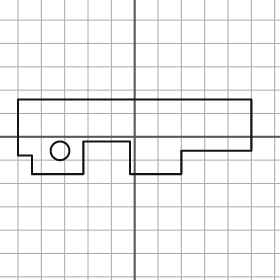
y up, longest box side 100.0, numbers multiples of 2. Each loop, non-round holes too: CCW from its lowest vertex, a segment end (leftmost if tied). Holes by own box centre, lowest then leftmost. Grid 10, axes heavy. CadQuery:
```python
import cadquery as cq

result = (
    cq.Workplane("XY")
    .moveTo(-44.0, -16.0)
    .lineTo(-22.0, -16.0)
    .lineTo(-22.0, -2.0)
    .lineTo(-2.0, -2.0)
    .lineTo(-2.0, -16.0)
    .lineTo(20.0, -16.0)
    .lineTo(20.0, -6.0)
    .lineTo(50.0, -6.0)
    .lineTo(50.0, 16.0)
    .lineTo(-50.0, 16.0)
    .lineTo(-50.0, -8.0)
    .lineTo(-44.0, -8.0)
    .close()
    .moveTo(-32.0, -6.0)
    .circle(4.0)
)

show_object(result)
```